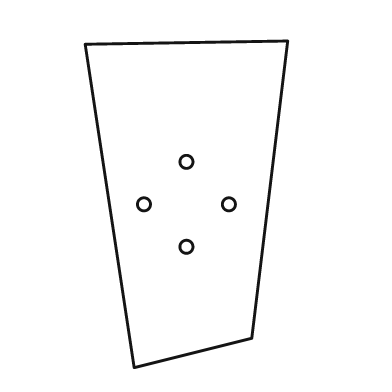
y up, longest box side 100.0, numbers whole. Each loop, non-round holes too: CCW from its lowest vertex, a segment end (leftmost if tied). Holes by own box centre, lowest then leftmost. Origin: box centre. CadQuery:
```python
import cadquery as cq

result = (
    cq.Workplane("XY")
    .moveTo(-16.0, -50.0)
    .lineTo(20.0, -41.0)
    .lineTo(31.0, 50.0)
    .lineTo(-31.0, 49.0)
    .close()
    .moveTo(0.0, -13.0)
    .circle(2.0)
    .moveTo(-13.0, 0.0)
    .circle(2.0)
    .moveTo(13.0, 0.0)
    .circle(2.0)
    .moveTo(0.0, 13.0)
    .circle(2.0)
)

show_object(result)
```